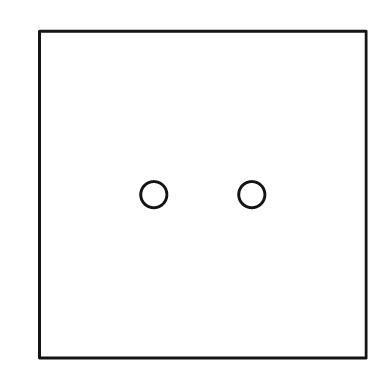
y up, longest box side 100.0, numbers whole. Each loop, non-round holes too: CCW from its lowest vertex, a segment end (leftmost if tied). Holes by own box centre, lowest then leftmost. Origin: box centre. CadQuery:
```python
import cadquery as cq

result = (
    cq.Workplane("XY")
    .moveTo(-50.0, -50.0)
    .lineTo(50.0, -50.0)
    .lineTo(50.0, 50.0)
    .lineTo(-50.0, 50.0)
    .close()
    .moveTo(-15.0, 0.0)
    .circle(4.0)
    .moveTo(15.0, 0.0)
    .circle(4.0)
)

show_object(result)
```